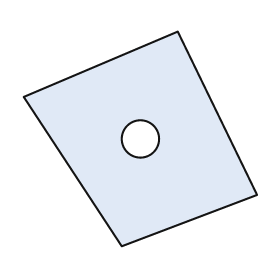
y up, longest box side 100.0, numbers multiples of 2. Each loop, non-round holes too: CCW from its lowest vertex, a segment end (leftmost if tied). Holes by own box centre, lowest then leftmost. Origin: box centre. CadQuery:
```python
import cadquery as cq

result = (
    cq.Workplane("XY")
    .moveTo(-8.0, -46.0)
    .lineTo(50.0, -24.0)
    .lineTo(16.0, 46.0)
    .lineTo(-50.0, 18.0)
    .close()
    .moveTo(0.0, 0.0)
    .circle(8.0)
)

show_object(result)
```